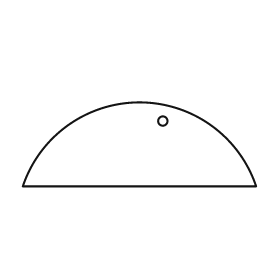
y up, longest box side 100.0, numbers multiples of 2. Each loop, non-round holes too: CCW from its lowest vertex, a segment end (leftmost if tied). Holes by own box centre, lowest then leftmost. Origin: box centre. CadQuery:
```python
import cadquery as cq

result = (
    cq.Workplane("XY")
    .moveTo(-50.0, -18.0)
    .lineTo(50.0, -18.0)
    .threePointArc((0.0, 18.0), (-50.0, -18.0))
    .close()
    .moveTo(10.0, 10.0)
    .circle(2.0)
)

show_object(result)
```